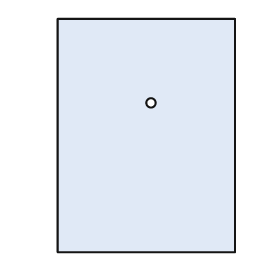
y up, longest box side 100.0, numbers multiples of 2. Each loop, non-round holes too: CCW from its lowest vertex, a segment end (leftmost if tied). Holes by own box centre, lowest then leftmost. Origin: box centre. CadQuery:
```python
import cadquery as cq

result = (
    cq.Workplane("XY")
    .moveTo(-38.0, -50.0)
    .lineTo(38.0, -50.0)
    .lineTo(38.0, 50.0)
    .lineTo(-38.0, 50.0)
    .close()
    .moveTo(2.0, 14.0)
    .circle(2.0)
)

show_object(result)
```